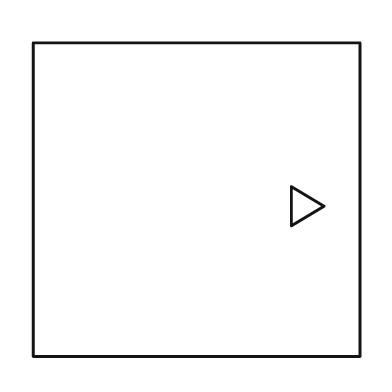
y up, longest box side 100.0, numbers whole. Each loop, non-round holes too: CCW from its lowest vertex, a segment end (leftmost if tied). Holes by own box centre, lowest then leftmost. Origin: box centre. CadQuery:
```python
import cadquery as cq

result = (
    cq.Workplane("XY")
    .moveTo(-50.0, -48.0)
    .lineTo(50.0, -48.0)
    .lineTo(50.0, 48.0)
    .lineTo(-50.0, 48.0)
    .close()
    .moveTo(29.0, -8.0)
    .lineTo(39.0, -2.0)
    .lineTo(29.0, 4.0)
    .close()
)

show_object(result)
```